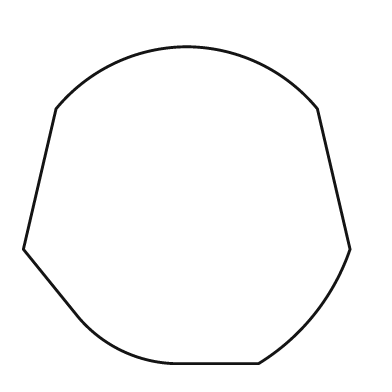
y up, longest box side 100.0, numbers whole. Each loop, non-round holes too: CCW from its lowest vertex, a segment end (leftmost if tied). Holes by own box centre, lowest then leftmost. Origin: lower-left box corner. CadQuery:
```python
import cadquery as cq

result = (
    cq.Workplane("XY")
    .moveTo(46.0, 0.0)
    .lineTo(72.0, 0.0)
    .threePointArc((89.0, 15.0), (100.0, 35.0))
    .lineTo(90.0, 78.0)
    .threePointArc((72.0, 92.0), (50.0, 97.0))
    .threePointArc((28.0, 92.0), (10.0, 78.0))
    .lineTo(0.0, 35.0)
    .lineTo(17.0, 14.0)
    .threePointArc((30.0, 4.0), (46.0, 0.0))
    .close()
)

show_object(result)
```